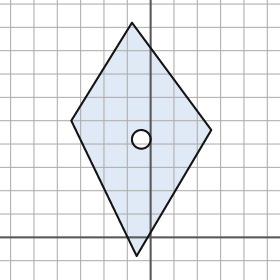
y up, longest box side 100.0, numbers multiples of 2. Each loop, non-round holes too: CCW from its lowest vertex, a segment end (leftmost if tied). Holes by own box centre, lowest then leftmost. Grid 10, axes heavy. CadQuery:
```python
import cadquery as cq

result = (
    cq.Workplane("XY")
    .moveTo(-6.0, -8.0)
    .lineTo(26.0, 46.0)
    .lineTo(-8.0, 92.0)
    .lineTo(-34.0, 50.0)
    .close()
    .moveTo(-4.0, 42.0)
    .circle(4.0)
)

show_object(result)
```